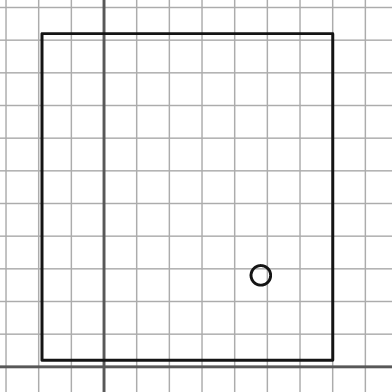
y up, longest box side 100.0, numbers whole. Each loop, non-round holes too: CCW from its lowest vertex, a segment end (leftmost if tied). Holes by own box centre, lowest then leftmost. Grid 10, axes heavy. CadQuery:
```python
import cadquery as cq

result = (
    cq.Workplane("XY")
    .moveTo(-19.0, 2.0)
    .lineTo(70.0, 2.0)
    .lineTo(70.0, 102.0)
    .lineTo(-19.0, 102.0)
    .close()
    .moveTo(48.0, 28.0)
    .circle(3.0)
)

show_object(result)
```